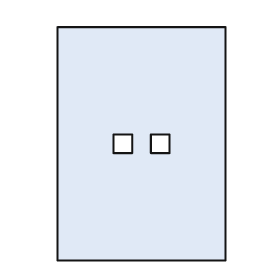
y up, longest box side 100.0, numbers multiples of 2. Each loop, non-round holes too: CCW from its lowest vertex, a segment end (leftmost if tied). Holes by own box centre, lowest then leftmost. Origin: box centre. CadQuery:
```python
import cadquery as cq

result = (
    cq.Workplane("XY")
    .moveTo(-36.0, -50.0)
    .lineTo(36.0, -50.0)
    .lineTo(36.0, 50.0)
    .lineTo(-36.0, 50.0)
    .close()
    .moveTo(-12.0, -4.0)
    .lineTo(-4.0, -4.0)
    .lineTo(-4.0, 4.0)
    .lineTo(-12.0, 4.0)
    .close()
    .moveTo(4.0, -4.0)
    .lineTo(12.0, -4.0)
    .lineTo(12.0, 4.0)
    .lineTo(4.0, 4.0)
    .close()
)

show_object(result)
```